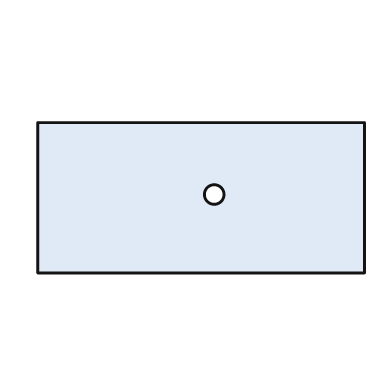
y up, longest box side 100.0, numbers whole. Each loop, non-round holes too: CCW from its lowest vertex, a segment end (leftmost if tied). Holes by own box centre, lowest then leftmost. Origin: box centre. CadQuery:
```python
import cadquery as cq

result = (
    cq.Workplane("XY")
    .moveTo(-50.0, -23.0)
    .lineTo(50.0, -23.0)
    .lineTo(50.0, 23.0)
    .lineTo(-50.0, 23.0)
    .close()
    .moveTo(4.0, 1.0)
    .circle(3.0)
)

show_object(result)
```